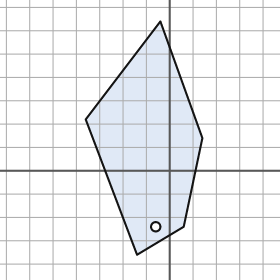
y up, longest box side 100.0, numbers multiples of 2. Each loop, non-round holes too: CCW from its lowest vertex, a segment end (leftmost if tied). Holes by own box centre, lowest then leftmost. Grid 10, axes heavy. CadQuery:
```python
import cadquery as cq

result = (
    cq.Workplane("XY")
    .moveTo(-14.0, -36.0)
    .lineTo(6.0, -24.0)
    .lineTo(14.0, 14.0)
    .lineTo(-4.0, 64.0)
    .lineTo(-36.0, 22.0)
    .close()
    .moveTo(-6.0, -24.0)
    .circle(2.0)
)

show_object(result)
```